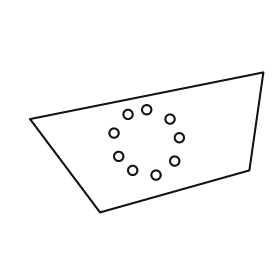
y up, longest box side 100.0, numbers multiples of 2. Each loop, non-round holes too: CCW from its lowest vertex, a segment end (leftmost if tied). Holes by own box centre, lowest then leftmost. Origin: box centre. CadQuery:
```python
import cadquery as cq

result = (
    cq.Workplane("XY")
    .moveTo(-20.0, -30.0)
    .lineTo(44.0, -12.0)
    .lineTo(50.0, 30.0)
    .lineTo(-50.0, 10.0)
    .close()
    .moveTo(4.0, -14.0)
    .circle(2.0)
    .moveTo(-6.0, -12.0)
    .circle(2.0)
    .moveTo(12.0, -8.0)
    .circle(2.0)
    .moveTo(-12.0, -6.0)
    .circle(2.0)
    .moveTo(14.0, 2.0)
    .circle(2.0)
    .moveTo(-14.0, 4.0)
    .circle(2.0)
    .moveTo(10.0, 10.0)
    .circle(2.0)
    .moveTo(-8.0, 12.0)
    .circle(2.0)
    .moveTo(0.0, 14.0)
    .circle(2.0)
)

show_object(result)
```